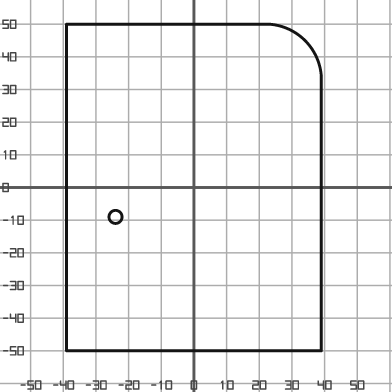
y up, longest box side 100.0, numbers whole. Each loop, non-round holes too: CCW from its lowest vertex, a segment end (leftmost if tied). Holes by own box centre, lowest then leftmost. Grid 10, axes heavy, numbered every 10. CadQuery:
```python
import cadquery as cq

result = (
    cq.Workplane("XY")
    .moveTo(-39.0, -50.0)
    .lineTo(39.0, -50.0)
    .lineTo(39.0, 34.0)
    .threePointArc((34.0, 45.0), (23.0, 50.0))
    .lineTo(-39.0, 50.0)
    .close()
    .moveTo(-24.0, -9.0)
    .circle(2.0)
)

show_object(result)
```